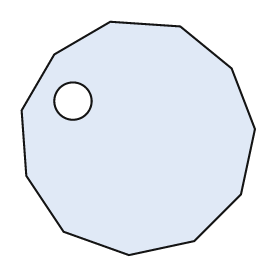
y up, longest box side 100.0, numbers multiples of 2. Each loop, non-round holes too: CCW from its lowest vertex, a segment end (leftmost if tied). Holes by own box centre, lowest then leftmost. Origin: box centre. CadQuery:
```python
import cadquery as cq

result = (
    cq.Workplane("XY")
    .moveTo(-4.0, -50.0)
    .lineTo(24.0, -44.0)
    .lineTo(44.0, -24.0)
    .lineTo(50.0, 4.0)
    .lineTo(40.0, 30.0)
    .lineTo(18.0, 48.0)
    .lineTo(-12.0, 50.0)
    .lineTo(-36.0, 36.0)
    .lineTo(-50.0, 12.0)
    .lineTo(-48.0, -16.0)
    .lineTo(-32.0, -40.0)
    .close()
    .moveTo(-28.0, 16.0)
    .circle(8.0)
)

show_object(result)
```